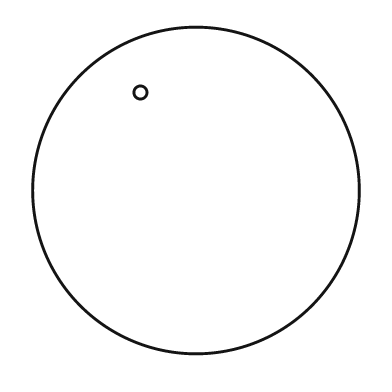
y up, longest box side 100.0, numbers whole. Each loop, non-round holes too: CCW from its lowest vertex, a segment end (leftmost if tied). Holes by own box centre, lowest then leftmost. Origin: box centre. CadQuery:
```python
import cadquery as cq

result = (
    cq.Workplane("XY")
    .moveTo(0.0, 0.0)
    .circle(50.0)
    .moveTo(-17.0, 30.0)
    .circle(2.0)
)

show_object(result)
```